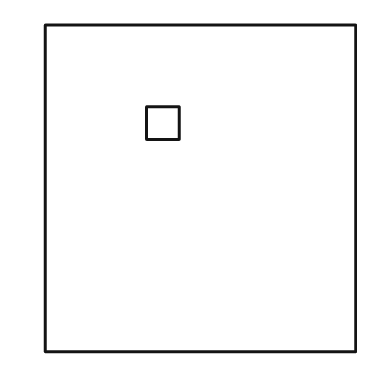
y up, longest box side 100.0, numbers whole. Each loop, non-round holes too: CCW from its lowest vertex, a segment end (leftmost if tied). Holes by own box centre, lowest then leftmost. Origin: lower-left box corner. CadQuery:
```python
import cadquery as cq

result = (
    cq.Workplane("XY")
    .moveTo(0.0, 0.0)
    .lineTo(95.0, 0.0)
    .lineTo(95.0, 100.0)
    .lineTo(0.0, 100.0)
    .close()
    .moveTo(31.0, 65.0)
    .lineTo(41.0, 65.0)
    .lineTo(41.0, 75.0)
    .lineTo(31.0, 75.0)
    .close()
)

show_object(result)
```